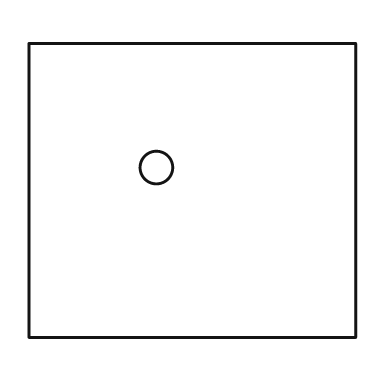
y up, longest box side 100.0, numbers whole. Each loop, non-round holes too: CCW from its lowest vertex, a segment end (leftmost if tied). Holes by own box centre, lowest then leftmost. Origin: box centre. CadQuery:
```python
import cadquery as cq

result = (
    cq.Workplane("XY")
    .moveTo(-50.0, -45.0)
    .lineTo(50.0, -45.0)
    .lineTo(50.0, 45.0)
    .lineTo(-50.0, 45.0)
    .close()
    .moveTo(-11.0, 7.0)
    .circle(5.0)
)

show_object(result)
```